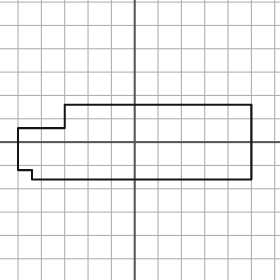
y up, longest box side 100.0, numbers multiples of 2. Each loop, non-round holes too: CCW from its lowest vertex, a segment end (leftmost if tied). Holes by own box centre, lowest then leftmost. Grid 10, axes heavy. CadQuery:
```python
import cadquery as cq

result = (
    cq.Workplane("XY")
    .moveTo(-44.0, -16.0)
    .lineTo(50.0, -16.0)
    .lineTo(50.0, 16.0)
    .lineTo(-30.0, 16.0)
    .lineTo(-30.0, 6.0)
    .lineTo(-50.0, 6.0)
    .lineTo(-50.0, -12.0)
    .lineTo(-44.0, -12.0)
    .close()
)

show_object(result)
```